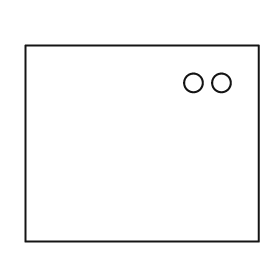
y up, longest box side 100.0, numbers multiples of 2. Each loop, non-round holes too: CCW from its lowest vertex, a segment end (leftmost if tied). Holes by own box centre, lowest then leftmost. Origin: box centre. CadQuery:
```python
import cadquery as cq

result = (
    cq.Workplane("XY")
    .moveTo(-50.0, -42.0)
    .lineTo(50.0, -42.0)
    .lineTo(50.0, 42.0)
    .lineTo(-50.0, 42.0)
    .close()
    .moveTo(22.0, 26.0)
    .circle(4.0)
    .moveTo(34.0, 26.0)
    .circle(4.0)
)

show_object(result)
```